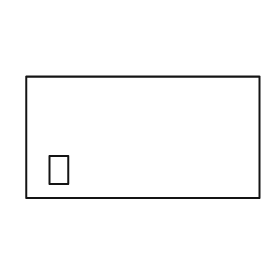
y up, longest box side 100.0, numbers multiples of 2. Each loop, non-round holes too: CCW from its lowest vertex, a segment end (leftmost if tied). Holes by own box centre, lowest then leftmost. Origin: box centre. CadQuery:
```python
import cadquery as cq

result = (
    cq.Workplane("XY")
    .moveTo(-50.0, -26.0)
    .lineTo(50.0, -26.0)
    .lineTo(50.0, 26.0)
    .lineTo(-50.0, 26.0)
    .close()
    .moveTo(-40.0, -20.0)
    .lineTo(-32.0, -20.0)
    .lineTo(-32.0, -8.0)
    .lineTo(-40.0, -8.0)
    .close()
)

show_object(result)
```